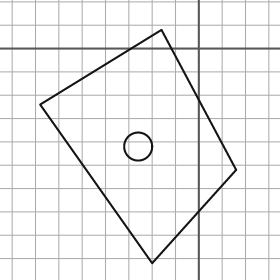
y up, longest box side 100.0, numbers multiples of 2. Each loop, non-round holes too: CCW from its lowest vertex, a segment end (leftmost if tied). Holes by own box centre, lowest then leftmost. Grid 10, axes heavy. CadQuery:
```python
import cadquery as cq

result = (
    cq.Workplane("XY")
    .moveTo(-20.0, -92.0)
    .lineTo(16.0, -52.0)
    .lineTo(-16.0, 8.0)
    .lineTo(-68.0, -24.0)
    .close()
    .moveTo(-26.0, -42.0)
    .circle(6.0)
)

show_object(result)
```